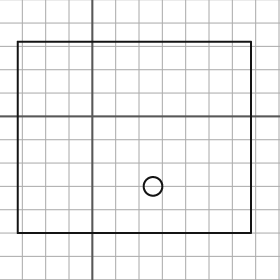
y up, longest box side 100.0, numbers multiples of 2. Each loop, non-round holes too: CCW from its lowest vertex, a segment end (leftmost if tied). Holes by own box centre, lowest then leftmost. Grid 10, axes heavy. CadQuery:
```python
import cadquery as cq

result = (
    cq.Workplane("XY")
    .moveTo(-32.0, -50.0)
    .lineTo(68.0, -50.0)
    .lineTo(68.0, 32.0)
    .lineTo(-32.0, 32.0)
    .close()
    .moveTo(26.0, -30.0)
    .circle(4.0)
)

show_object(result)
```